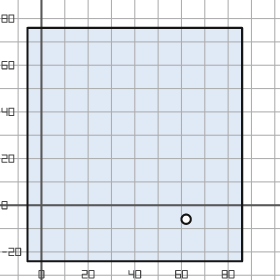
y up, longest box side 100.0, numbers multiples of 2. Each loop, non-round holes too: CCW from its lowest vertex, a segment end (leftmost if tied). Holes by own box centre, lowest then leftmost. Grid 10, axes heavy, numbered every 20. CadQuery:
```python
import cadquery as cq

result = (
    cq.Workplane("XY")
    .moveTo(-6.0, -24.0)
    .lineTo(86.0, -24.0)
    .lineTo(86.0, 76.0)
    .lineTo(-6.0, 76.0)
    .close()
    .moveTo(62.0, -6.0)
    .circle(2.0)
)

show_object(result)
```